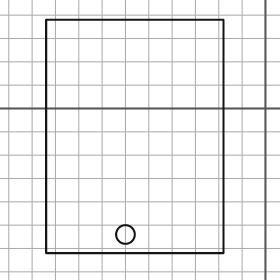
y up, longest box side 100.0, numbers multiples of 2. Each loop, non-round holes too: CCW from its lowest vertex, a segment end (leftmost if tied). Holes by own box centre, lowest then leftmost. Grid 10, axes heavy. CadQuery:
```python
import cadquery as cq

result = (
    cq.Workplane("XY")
    .moveTo(-94.0, -62.0)
    .lineTo(-18.0, -62.0)
    .lineTo(-18.0, 38.0)
    .lineTo(-94.0, 38.0)
    .close()
    .moveTo(-60.0, -54.0)
    .circle(4.0)
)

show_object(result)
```